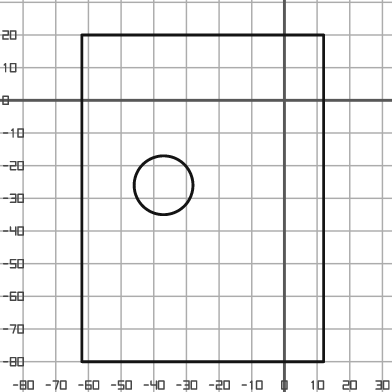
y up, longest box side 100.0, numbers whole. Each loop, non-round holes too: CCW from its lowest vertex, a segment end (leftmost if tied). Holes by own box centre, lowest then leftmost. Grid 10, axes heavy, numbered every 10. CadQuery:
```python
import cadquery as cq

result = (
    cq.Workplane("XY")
    .moveTo(-62.0, -80.0)
    .lineTo(12.0, -80.0)
    .lineTo(12.0, 20.0)
    .lineTo(-62.0, 20.0)
    .close()
    .moveTo(-37.0, -26.0)
    .circle(9.0)
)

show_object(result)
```